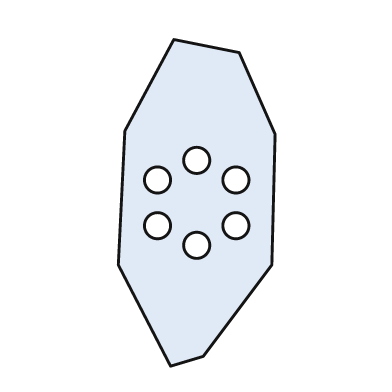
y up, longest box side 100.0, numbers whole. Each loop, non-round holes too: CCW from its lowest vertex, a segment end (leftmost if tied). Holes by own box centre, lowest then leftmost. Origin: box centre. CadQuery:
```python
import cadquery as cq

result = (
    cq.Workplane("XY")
    .moveTo(-8.0, -50.0)
    .lineTo(2.0, -47.0)
    .lineTo(23.0, -19.0)
    .lineTo(24.0, 21.0)
    .lineTo(13.0, 46.0)
    .lineTo(-7.0, 50.0)
    .lineTo(-22.0, 22.0)
    .lineTo(-24.0, -19.0)
    .close()
    .moveTo(0.0, -13.0)
    .circle(4.0)
    .moveTo(-12.0, -7.0)
    .circle(4.0)
    .moveTo(12.0, -7.0)
    .circle(4.0)
    .moveTo(-12.0, 7.0)
    .circle(4.0)
    .moveTo(12.0, 7.0)
    .circle(4.0)
    .moveTo(0.0, 13.0)
    .circle(4.0)
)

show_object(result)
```